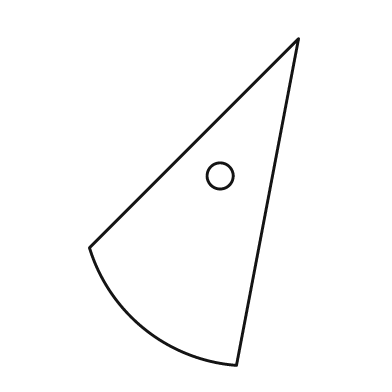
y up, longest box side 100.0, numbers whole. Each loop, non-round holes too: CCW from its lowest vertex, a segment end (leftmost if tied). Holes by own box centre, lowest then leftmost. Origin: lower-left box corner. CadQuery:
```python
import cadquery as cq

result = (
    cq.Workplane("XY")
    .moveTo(45.0, 0.0)
    .lineTo(64.0, 100.0)
    .lineTo(0.0, 36.0)
    .threePointArc((17.0, 11.0), (45.0, 0.0))
    .close()
    .moveTo(40.0, 58.0)
    .circle(4.0)
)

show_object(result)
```